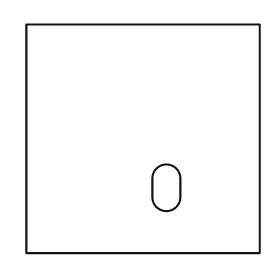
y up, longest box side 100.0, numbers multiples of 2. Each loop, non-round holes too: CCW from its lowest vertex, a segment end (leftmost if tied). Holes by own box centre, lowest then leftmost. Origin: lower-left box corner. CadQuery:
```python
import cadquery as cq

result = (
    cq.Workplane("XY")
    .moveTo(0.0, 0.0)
    .lineTo(100.0, 0.0)
    .lineTo(100.0, 98.0)
    .lineTo(0.0, 98.0)
    .close()
    .moveTo(54.0, 24.0)
    .threePointArc((60.0, 18.0), (66.0, 24.0))
    .lineTo(66.0, 32.0)
    .threePointArc((60.0, 38.0), (54.0, 32.0))
    .close()
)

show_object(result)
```